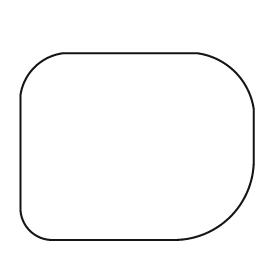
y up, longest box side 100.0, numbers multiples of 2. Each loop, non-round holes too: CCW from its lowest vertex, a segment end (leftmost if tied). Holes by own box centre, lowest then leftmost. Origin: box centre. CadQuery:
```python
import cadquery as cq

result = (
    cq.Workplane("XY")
    .moveTo(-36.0, -40.0)
    .lineTo(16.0, -40.0)
    .threePointArc((40.0, -30.0), (50.0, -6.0))
    .lineTo(50.0, 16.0)
    .threePointArc((42.0, 32.0), (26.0, 40.0))
    .lineTo(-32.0, 40.0)
    .threePointArc((-44.0, 34.0), (-50.0, 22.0))
    .lineTo(-50.0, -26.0)
    .threePointArc((-46.0, -36.0), (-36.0, -40.0))
    .close()
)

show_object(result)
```